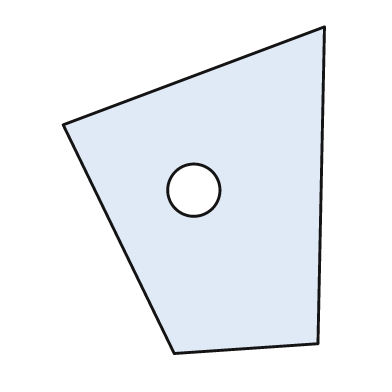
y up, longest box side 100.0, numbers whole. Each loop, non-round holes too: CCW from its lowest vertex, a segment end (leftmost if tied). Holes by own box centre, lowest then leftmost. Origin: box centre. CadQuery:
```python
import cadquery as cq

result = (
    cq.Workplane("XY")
    .moveTo(-6.0, -50.0)
    .lineTo(38.0, -47.0)
    .lineTo(40.0, 50.0)
    .lineTo(-40.0, 20.0)
    .close()
    .moveTo(0.0, 0.0)
    .circle(8.0)
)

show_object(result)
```